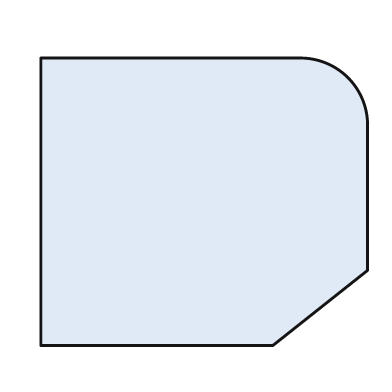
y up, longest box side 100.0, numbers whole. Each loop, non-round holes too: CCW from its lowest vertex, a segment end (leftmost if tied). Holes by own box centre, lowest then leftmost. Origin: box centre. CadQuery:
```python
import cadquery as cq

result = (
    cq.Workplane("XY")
    .moveTo(-50.0, -44.0)
    .lineTo(21.0, -44.0)
    .lineTo(50.0, -21.0)
    .lineTo(50.0, 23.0)
    .threePointArc((44.0, 38.0), (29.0, 44.0))
    .lineTo(-50.0, 44.0)
    .close()
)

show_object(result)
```